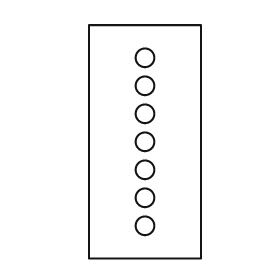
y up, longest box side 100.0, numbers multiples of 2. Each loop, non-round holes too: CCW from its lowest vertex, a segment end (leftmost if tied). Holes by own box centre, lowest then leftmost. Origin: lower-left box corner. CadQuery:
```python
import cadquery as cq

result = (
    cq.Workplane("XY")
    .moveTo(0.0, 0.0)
    .lineTo(48.0, 0.0)
    .lineTo(48.0, 100.0)
    .lineTo(0.0, 100.0)
    .close()
    .moveTo(24.0, 14.0)
    .circle(4.0)
    .moveTo(24.0, 26.0)
    .circle(4.0)
    .moveTo(24.0, 38.0)
    .circle(4.0)
    .moveTo(24.0, 50.0)
    .circle(4.0)
    .moveTo(24.0, 62.0)
    .circle(4.0)
    .moveTo(24.0, 74.0)
    .circle(4.0)
    .moveTo(24.0, 86.0)
    .circle(4.0)
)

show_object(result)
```